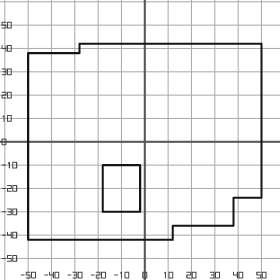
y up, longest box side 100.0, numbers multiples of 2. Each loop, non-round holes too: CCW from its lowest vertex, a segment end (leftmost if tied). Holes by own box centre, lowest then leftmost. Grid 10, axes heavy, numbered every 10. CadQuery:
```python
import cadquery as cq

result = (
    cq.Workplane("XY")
    .moveTo(-50.0, -42.0)
    .lineTo(12.0, -42.0)
    .lineTo(12.0, -36.0)
    .lineTo(38.0, -36.0)
    .lineTo(38.0, -24.0)
    .lineTo(50.0, -24.0)
    .lineTo(50.0, 42.0)
    .lineTo(-28.0, 42.0)
    .lineTo(-28.0, 38.0)
    .lineTo(-50.0, 38.0)
    .close()
    .moveTo(-18.0, -30.0)
    .lineTo(-2.0, -30.0)
    .lineTo(-2.0, -10.0)
    .lineTo(-18.0, -10.0)
    .close()
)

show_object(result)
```